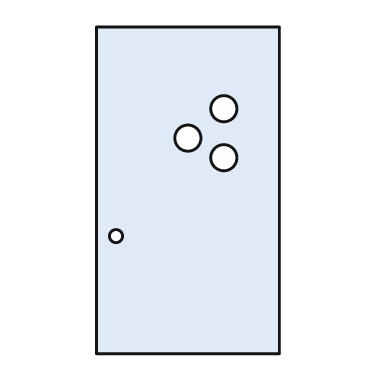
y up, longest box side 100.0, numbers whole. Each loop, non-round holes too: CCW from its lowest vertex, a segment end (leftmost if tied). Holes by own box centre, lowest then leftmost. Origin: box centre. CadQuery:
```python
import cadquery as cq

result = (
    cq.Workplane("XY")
    .moveTo(-28.0, -50.0)
    .lineTo(28.0, -50.0)
    .lineTo(28.0, 50.0)
    .lineTo(-28.0, 50.0)
    .close()
    .moveTo(-22.0, -14.0)
    .circle(2.0)
    .moveTo(11.0, 10.0)
    .circle(4.0)
    .moveTo(0.0, 16.0)
    .circle(4.0)
    .moveTo(11.0, 25.0)
    .circle(4.0)
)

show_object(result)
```